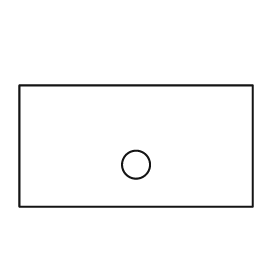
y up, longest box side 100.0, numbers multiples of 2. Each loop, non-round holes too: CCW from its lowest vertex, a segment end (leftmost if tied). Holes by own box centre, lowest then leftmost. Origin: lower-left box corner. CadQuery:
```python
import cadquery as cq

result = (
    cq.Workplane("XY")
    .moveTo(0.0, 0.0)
    .lineTo(100.0, 0.0)
    .lineTo(100.0, 52.0)
    .lineTo(0.0, 52.0)
    .close()
    .moveTo(50.0, 18.0)
    .circle(6.0)
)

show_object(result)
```